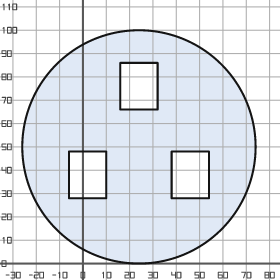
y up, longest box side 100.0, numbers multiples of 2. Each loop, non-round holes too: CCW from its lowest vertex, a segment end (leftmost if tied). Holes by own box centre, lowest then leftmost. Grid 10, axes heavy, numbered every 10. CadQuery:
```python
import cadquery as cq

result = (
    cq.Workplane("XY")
    .moveTo(24.0, 50.0)
    .circle(50.0)
    .moveTo(-6.0, 28.0)
    .lineTo(10.0, 28.0)
    .lineTo(10.0, 48.0)
    .lineTo(-6.0, 48.0)
    .close()
    .moveTo(38.0, 28.0)
    .lineTo(54.0, 28.0)
    .lineTo(54.0, 48.0)
    .lineTo(38.0, 48.0)
    .close()
    .moveTo(16.0, 66.0)
    .lineTo(32.0, 66.0)
    .lineTo(32.0, 86.0)
    .lineTo(16.0, 86.0)
    .close()
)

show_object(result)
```